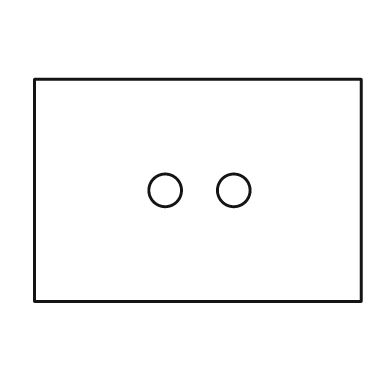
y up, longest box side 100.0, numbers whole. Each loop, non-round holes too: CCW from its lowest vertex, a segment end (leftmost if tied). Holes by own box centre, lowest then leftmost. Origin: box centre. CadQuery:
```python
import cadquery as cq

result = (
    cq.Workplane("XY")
    .moveTo(-50.0, -34.0)
    .lineTo(50.0, -34.0)
    .lineTo(50.0, 34.0)
    .lineTo(-50.0, 34.0)
    .close()
    .moveTo(-10.0, 0.0)
    .circle(5.0)
    .moveTo(11.0, 0.0)
    .circle(5.0)
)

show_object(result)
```